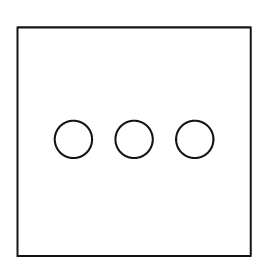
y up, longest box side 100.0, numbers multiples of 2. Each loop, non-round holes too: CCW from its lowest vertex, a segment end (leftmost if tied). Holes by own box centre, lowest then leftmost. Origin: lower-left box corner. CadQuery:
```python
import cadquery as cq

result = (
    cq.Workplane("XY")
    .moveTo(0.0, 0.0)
    .lineTo(100.0, 0.0)
    .lineTo(100.0, 98.0)
    .lineTo(0.0, 98.0)
    .close()
    .moveTo(24.0, 50.0)
    .circle(8.0)
    .moveTo(50.0, 50.0)
    .circle(8.0)
    .moveTo(76.0, 50.0)
    .circle(8.0)
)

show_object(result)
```